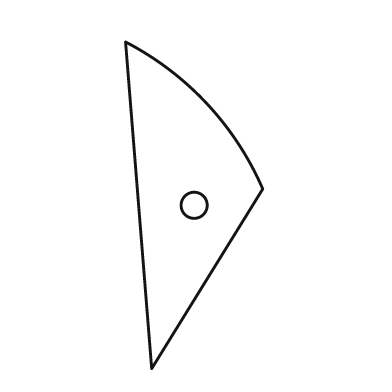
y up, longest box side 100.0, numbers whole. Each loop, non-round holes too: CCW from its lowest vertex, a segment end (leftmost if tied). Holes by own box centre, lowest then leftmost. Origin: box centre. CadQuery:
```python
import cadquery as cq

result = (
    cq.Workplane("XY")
    .moveTo(-13.0, -50.0)
    .lineTo(21.0, 5.0)
    .threePointArc((4.0, 31.0), (-21.0, 50.0))
    .close()
    .moveTo(0.0, 0.0)
    .circle(4.0)
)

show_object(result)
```